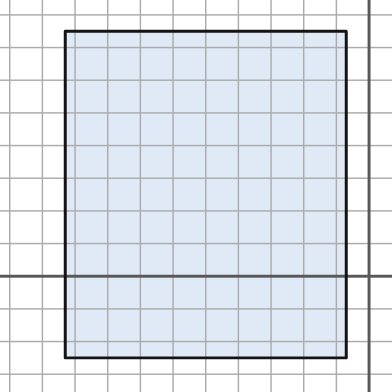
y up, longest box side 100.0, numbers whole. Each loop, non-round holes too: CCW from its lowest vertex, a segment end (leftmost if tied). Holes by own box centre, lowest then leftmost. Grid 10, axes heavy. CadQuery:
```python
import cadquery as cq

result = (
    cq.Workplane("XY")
    .moveTo(-93.0, -25.0)
    .lineTo(-7.0, -25.0)
    .lineTo(-7.0, 75.0)
    .lineTo(-93.0, 75.0)
    .close()
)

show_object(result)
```